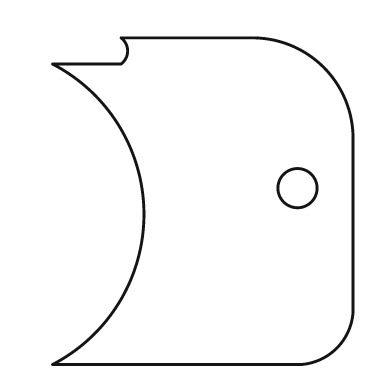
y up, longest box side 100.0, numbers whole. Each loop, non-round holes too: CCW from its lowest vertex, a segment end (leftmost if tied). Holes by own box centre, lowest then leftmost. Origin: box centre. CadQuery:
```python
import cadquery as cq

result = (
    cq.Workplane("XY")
    .moveTo(-46.0, -50.0)
    .lineTo(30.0, -50.0)
    .threePointArc((41.0, -45.0), (46.0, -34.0))
    .lineTo(46.0, 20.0)
    .threePointArc((37.0, 41.0), (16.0, 50.0))
    .lineTo(-25.0, 50.0)
    .threePointArc((-23.0, 46.0), (-25.0, 42.0))
    .lineTo(-46.0, 42.0)
    .threePointArc((-18.0, -4.0), (-46.0, -50.0))
    .close()
    .moveTo(29.0, 4.0)
    .circle(6.0)
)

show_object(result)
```